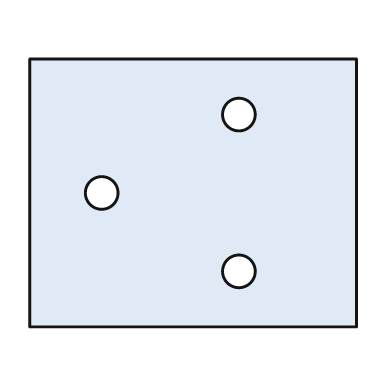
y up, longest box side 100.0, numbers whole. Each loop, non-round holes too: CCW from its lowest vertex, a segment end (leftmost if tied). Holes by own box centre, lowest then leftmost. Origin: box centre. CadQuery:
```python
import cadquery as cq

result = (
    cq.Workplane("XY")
    .moveTo(-50.0, -41.0)
    .lineTo(50.0, -41.0)
    .lineTo(50.0, 41.0)
    .lineTo(-50.0, 41.0)
    .close()
    .moveTo(14.0, -24.0)
    .circle(5.0)
    .moveTo(-28.0, 0.0)
    .circle(5.0)
    .moveTo(14.0, 24.0)
    .circle(5.0)
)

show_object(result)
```